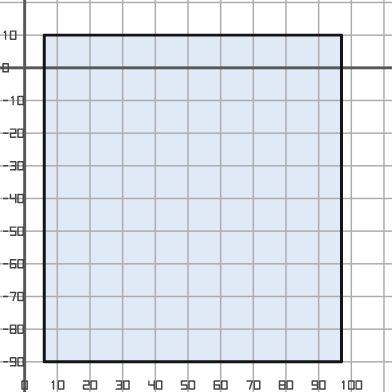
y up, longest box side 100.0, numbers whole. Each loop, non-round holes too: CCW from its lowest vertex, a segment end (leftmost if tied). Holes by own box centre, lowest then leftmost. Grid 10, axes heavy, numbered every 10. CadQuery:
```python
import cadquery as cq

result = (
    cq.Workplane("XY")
    .moveTo(6.0, -90.0)
    .lineTo(97.0, -90.0)
    .lineTo(97.0, 10.0)
    .lineTo(6.0, 10.0)
    .close()
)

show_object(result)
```